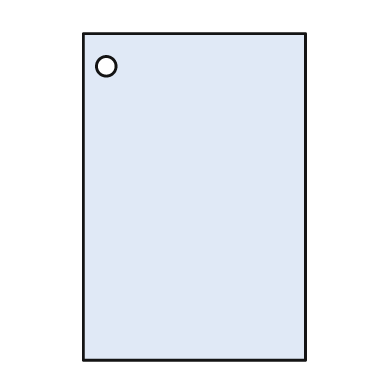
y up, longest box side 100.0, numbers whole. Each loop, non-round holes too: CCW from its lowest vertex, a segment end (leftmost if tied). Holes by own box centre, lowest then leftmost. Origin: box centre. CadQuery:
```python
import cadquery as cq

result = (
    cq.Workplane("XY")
    .moveTo(-34.0, -50.0)
    .lineTo(34.0, -50.0)
    .lineTo(34.0, 50.0)
    .lineTo(-34.0, 50.0)
    .close()
    .moveTo(-27.0, 40.0)
    .circle(3.0)
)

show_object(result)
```